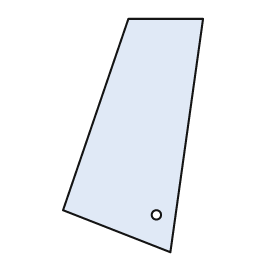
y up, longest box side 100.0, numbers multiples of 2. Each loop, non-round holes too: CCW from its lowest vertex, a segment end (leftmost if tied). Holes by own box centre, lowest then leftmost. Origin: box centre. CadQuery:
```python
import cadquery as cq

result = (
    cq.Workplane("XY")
    .moveTo(16.0, -50.0)
    .lineTo(30.0, 50.0)
    .lineTo(-2.0, 50.0)
    .lineTo(-30.0, -32.0)
    .close()
    .moveTo(10.0, -34.0)
    .circle(2.0)
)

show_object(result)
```